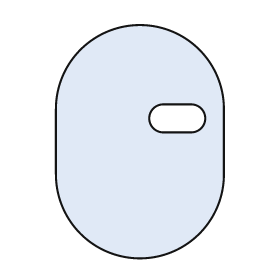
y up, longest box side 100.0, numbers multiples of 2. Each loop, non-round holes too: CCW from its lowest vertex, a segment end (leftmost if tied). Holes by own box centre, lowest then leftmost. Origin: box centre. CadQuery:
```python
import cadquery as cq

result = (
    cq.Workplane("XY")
    .moveTo(-36.0, -14.0)
    .threePointArc((0.0, -50.0), (36.0, -14.0))
    .lineTo(36.0, 14.0)
    .threePointArc((0.0, 50.0), (-36.0, 14.0))
    .close()
    .moveTo(10.0, 4.0)
    .lineTo(22.0, 4.0)
    .threePointArc((28.0, 10.0), (22.0, 16.0))
    .lineTo(10.0, 16.0)
    .threePointArc((4.0, 10.0), (10.0, 4.0))
    .close()
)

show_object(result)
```